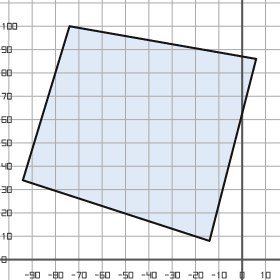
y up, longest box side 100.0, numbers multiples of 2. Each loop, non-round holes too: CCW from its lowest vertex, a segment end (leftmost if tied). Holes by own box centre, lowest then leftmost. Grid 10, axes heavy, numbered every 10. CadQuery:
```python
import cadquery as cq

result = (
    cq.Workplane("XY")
    .moveTo(-14.0, 8.0)
    .lineTo(6.0, 86.0)
    .lineTo(-74.0, 100.0)
    .lineTo(-94.0, 34.0)
    .close()
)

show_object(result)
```